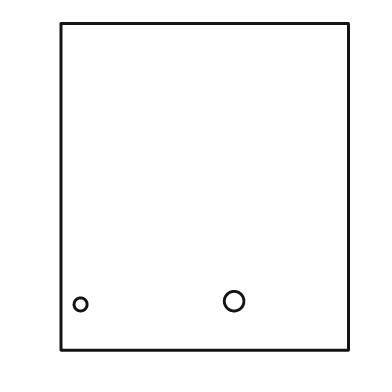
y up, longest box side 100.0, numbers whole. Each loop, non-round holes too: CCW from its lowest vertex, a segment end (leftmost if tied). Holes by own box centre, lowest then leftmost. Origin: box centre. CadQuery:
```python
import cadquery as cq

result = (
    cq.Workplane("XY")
    .moveTo(-44.0, -50.0)
    .lineTo(44.0, -50.0)
    .lineTo(44.0, 50.0)
    .lineTo(-44.0, 50.0)
    .close()
    .moveTo(-38.0, -36.0)
    .circle(2.0)
    .moveTo(9.0, -35.0)
    .circle(3.0)
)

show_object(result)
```